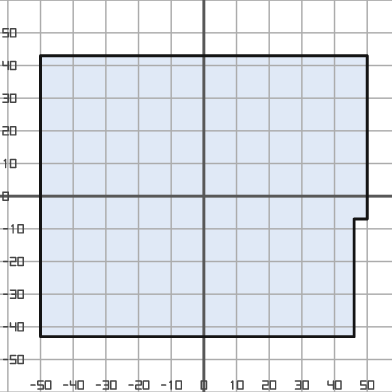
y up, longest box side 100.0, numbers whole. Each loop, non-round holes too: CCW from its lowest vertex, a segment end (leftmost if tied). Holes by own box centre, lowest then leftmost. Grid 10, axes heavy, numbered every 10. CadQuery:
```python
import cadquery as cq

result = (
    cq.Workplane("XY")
    .moveTo(-50.0, -43.0)
    .lineTo(46.0, -43.0)
    .lineTo(46.0, -7.0)
    .lineTo(50.0, -7.0)
    .lineTo(50.0, 43.0)
    .lineTo(-50.0, 43.0)
    .close()
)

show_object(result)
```